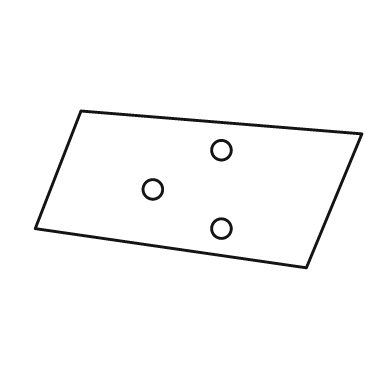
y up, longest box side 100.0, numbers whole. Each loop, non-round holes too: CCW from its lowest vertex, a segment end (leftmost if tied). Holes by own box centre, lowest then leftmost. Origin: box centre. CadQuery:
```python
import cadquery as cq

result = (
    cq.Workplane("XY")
    .moveTo(33.0, -24.0)
    .lineTo(50.0, 17.0)
    .lineTo(-36.0, 24.0)
    .lineTo(-50.0, -12.0)
    .close()
    .moveTo(7.0, -12.0)
    .circle(3.0)
    .moveTo(-14.0, 0.0)
    .circle(3.0)
    .moveTo(7.0, 12.0)
    .circle(3.0)
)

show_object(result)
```